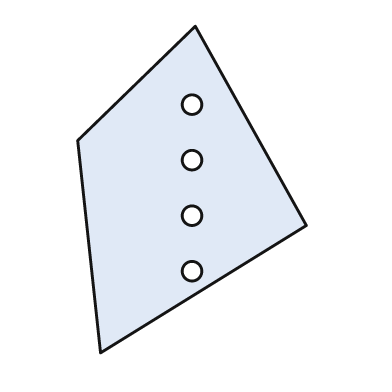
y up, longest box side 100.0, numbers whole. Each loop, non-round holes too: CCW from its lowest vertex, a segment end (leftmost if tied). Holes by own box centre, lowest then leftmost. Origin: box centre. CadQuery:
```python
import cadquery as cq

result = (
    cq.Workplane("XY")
    .moveTo(-28.0, -50.0)
    .lineTo(35.0, -11.0)
    .lineTo(1.0, 50.0)
    .lineTo(-35.0, 15.0)
    .close()
    .moveTo(0.0, -25.0)
    .circle(3.0)
    .moveTo(0.0, -8.0)
    .circle(3.0)
    .moveTo(0.0, 9.0)
    .circle(3.0)
    .moveTo(0.0, 26.0)
    .circle(3.0)
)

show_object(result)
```